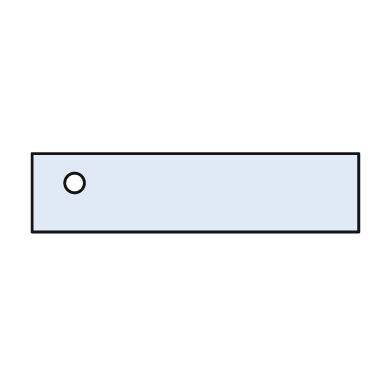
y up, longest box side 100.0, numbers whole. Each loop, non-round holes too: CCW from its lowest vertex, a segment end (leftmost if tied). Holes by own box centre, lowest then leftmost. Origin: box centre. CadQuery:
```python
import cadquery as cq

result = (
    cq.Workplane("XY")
    .moveTo(-50.0, -12.0)
    .lineTo(50.0, -12.0)
    .lineTo(50.0, 12.0)
    .lineTo(-50.0, 12.0)
    .close()
    .moveTo(-37.0, 3.0)
    .circle(3.0)
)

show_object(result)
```